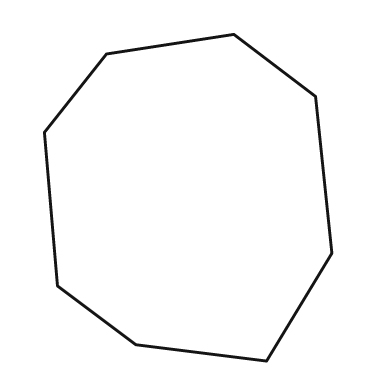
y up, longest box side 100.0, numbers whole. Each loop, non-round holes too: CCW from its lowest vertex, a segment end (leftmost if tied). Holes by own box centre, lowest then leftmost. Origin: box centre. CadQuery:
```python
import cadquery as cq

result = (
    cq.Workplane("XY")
    .moveTo(24.0, -50.0)
    .lineTo(44.0, -17.0)
    .lineTo(39.0, 31.0)
    .lineTo(14.0, 50.0)
    .lineTo(-25.0, 44.0)
    .lineTo(-44.0, 20.0)
    .lineTo(-40.0, -27.0)
    .lineTo(-16.0, -45.0)
    .close()
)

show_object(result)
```